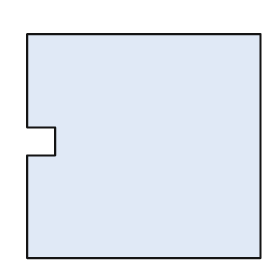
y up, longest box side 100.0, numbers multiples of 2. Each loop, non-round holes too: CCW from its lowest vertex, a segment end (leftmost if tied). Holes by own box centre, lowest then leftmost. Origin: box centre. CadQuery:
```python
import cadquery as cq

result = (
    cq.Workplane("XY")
    .moveTo(-50.0, -48.0)
    .lineTo(50.0, -48.0)
    .lineTo(50.0, 48.0)
    .lineTo(-50.0, 48.0)
    .lineTo(-50.0, 8.0)
    .lineTo(-38.0, 8.0)
    .lineTo(-38.0, -4.0)
    .lineTo(-50.0, -4.0)
    .close()
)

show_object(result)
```